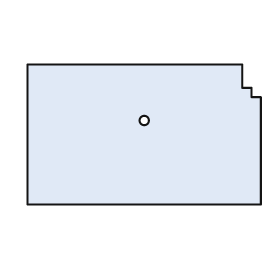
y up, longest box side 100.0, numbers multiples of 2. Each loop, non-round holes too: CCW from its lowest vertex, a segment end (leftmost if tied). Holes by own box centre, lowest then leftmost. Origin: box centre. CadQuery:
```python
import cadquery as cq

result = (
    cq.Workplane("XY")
    .moveTo(-50.0, -30.0)
    .lineTo(50.0, -30.0)
    .lineTo(50.0, 16.0)
    .lineTo(46.0, 16.0)
    .lineTo(46.0, 20.0)
    .lineTo(42.0, 20.0)
    .lineTo(42.0, 30.0)
    .lineTo(-50.0, 30.0)
    .close()
    .moveTo(0.0, 6.0)
    .circle(2.0)
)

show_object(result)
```